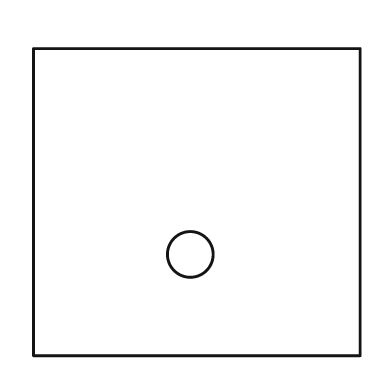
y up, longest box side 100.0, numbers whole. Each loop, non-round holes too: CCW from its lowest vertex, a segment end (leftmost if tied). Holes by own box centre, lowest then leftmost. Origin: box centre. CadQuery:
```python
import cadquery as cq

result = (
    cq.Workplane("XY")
    .moveTo(-50.0, -47.0)
    .lineTo(50.0, -47.0)
    .lineTo(50.0, 47.0)
    .lineTo(-50.0, 47.0)
    .close()
    .moveTo(-2.0, -16.0)
    .circle(7.0)
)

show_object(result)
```